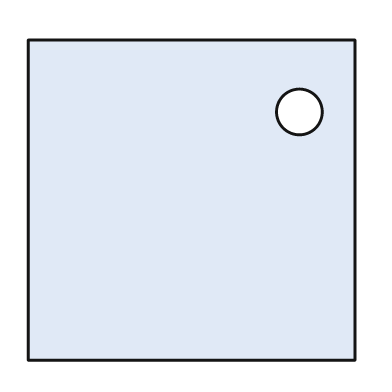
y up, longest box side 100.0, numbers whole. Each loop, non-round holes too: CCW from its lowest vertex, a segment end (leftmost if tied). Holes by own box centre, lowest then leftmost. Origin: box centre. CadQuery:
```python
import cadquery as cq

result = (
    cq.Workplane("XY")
    .moveTo(-50.0, -49.0)
    .lineTo(50.0, -49.0)
    .lineTo(50.0, 49.0)
    .lineTo(-50.0, 49.0)
    .close()
    .moveTo(33.0, 27.0)
    .circle(7.0)
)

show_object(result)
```